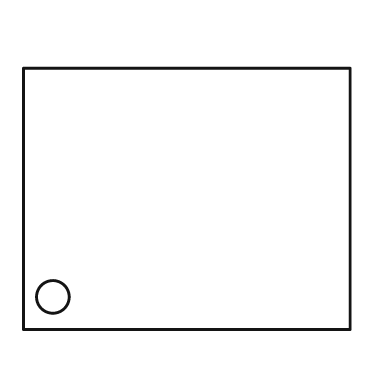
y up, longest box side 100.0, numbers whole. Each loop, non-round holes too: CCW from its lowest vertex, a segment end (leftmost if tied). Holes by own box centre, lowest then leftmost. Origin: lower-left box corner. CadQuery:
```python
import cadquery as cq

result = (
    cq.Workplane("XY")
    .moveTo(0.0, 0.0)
    .lineTo(100.0, 0.0)
    .lineTo(100.0, 80.0)
    .lineTo(0.0, 80.0)
    .close()
    .moveTo(9.0, 10.0)
    .circle(5.0)
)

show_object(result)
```